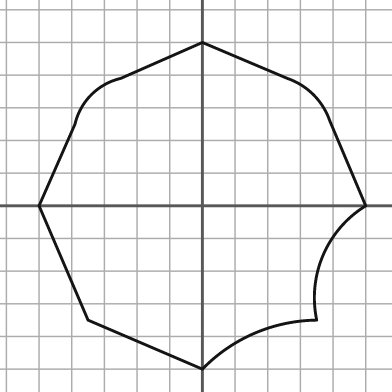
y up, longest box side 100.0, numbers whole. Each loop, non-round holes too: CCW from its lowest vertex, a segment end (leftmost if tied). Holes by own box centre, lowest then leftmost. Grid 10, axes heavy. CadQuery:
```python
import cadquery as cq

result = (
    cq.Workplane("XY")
    .moveTo(0.0, -50.0)
    .threePointArc((16.0, -39.0), (35.0, -35.0))
    .threePointArc((37.0, -15.0), (50.0, 0.0))
    .lineTo(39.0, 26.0)
    .threePointArc((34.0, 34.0), (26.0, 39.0))
    .lineTo(0.0, 50.0)
    .lineTo(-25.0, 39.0)
    .threePointArc((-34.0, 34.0), (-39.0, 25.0))
    .lineTo(-50.0, 0.0)
    .lineTo(-35.0, -35.0)
    .close()
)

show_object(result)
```